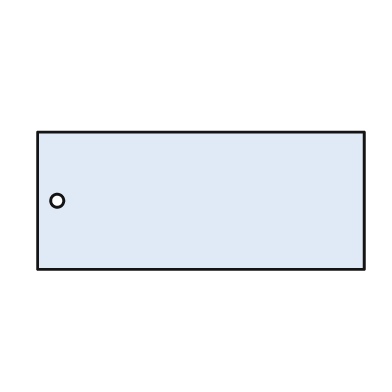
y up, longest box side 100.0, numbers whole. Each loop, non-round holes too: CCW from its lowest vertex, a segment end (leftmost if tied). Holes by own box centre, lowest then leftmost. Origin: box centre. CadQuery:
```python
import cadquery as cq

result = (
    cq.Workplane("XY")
    .moveTo(-50.0, -21.0)
    .lineTo(50.0, -21.0)
    .lineTo(50.0, 21.0)
    .lineTo(-50.0, 21.0)
    .close()
    .moveTo(-44.0, 0.0)
    .circle(2.0)
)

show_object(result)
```